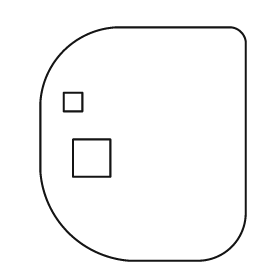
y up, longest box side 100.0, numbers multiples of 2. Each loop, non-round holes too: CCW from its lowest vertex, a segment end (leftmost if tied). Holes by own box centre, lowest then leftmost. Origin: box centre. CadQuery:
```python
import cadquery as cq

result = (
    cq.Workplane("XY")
    .moveTo(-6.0, -50.0)
    .lineTo(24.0, -50.0)
    .threePointArc((38.0, -44.0), (44.0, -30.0))
    .lineTo(44.0, 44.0)
    .threePointArc((42.0, 48.0), (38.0, 50.0))
    .lineTo(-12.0, 50.0)
    .threePointArc((-34.0, 40.0), (-44.0, 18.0))
    .lineTo(-44.0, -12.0)
    .threePointArc((-32.0, -38.0), (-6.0, -50.0))
    .close()
    .moveTo(-30.0, -14.0)
    .lineTo(-14.0, -14.0)
    .lineTo(-14.0, 2.0)
    .lineTo(-30.0, 2.0)
    .close()
    .moveTo(-34.0, 14.0)
    .lineTo(-26.0, 14.0)
    .lineTo(-26.0, 22.0)
    .lineTo(-34.0, 22.0)
    .close()
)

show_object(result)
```